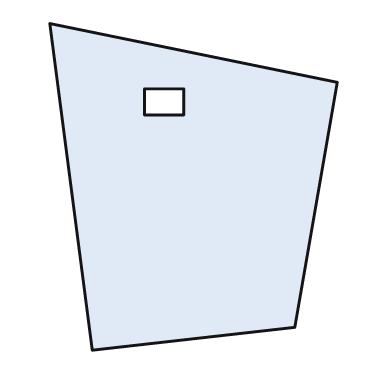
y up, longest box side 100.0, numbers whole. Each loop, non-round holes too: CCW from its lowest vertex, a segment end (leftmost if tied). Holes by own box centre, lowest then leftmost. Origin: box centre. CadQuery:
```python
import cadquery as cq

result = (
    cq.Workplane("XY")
    .moveTo(-31.0, -50.0)
    .lineTo(31.0, -43.0)
    .lineTo(44.0, 32.0)
    .lineTo(-44.0, 50.0)
    .close()
    .moveTo(-15.0, 22.0)
    .lineTo(-3.0, 22.0)
    .lineTo(-3.0, 30.0)
    .lineTo(-15.0, 30.0)
    .close()
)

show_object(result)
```